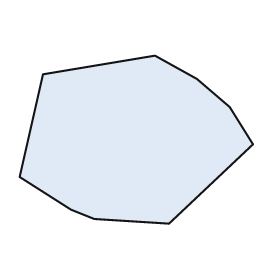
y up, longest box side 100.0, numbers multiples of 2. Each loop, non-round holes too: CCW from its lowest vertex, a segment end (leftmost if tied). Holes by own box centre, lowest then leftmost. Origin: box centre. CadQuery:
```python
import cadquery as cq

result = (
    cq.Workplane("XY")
    .moveTo(14.0, -36.0)
    .lineTo(50.0, -2.0)
    .lineTo(40.0, 14.0)
    .lineTo(26.0, 26.0)
    .lineTo(8.0, 36.0)
    .lineTo(-40.0, 28.0)
    .lineTo(-50.0, -16.0)
    .lineTo(-28.0, -30.0)
    .lineTo(-18.0, -34.0)
    .close()
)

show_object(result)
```